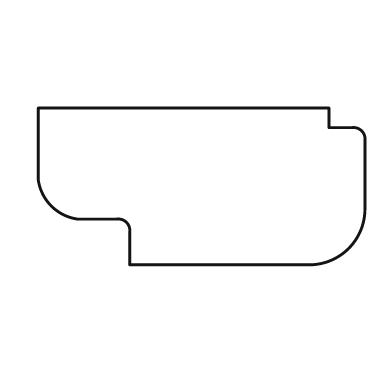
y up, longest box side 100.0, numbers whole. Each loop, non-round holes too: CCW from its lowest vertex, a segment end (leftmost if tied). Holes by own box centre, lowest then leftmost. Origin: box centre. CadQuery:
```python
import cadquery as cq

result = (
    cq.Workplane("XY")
    .moveTo(-22.0, -24.0)
    .lineTo(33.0, -24.0)
    .threePointArc((45.0, -19.0), (50.0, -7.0))
    .lineTo(50.0, 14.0)
    .threePointArc((49.0, 17.0), (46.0, 18.0))
    .lineTo(39.0, 18.0)
    .lineTo(39.0, 24.0)
    .lineTo(-50.0, 24.0)
    .lineTo(-50.0, 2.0)
    .threePointArc((-46.0, -6.0), (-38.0, -10.0))
    .lineTo(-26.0, -10.0)
    .threePointArc((-23.0, -11.0), (-22.0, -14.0))
    .close()
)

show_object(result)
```